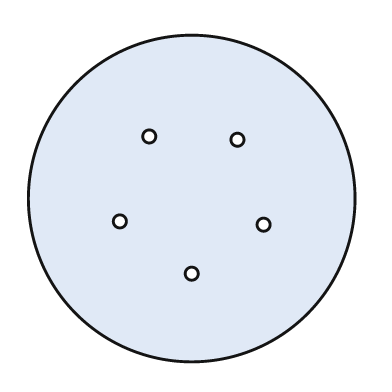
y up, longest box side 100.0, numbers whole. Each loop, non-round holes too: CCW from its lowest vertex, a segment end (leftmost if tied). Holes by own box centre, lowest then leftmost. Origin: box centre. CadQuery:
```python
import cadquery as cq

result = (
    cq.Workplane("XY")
    .moveTo(0.0, 0.0)
    .circle(50.0)
    .moveTo(0.0, -23.0)
    .circle(2.0)
    .moveTo(22.0, -8.0)
    .circle(2.0)
    .moveTo(-22.0, -7.0)
    .circle(2.0)
    .moveTo(14.0, 18.0)
    .circle(2.0)
    .moveTo(-13.0, 19.0)
    .circle(2.0)
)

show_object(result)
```